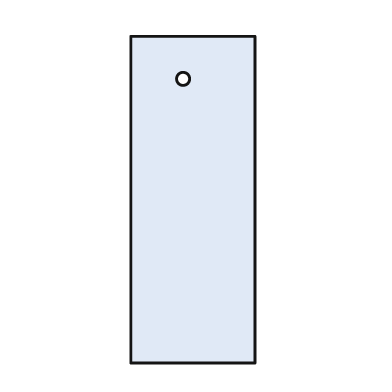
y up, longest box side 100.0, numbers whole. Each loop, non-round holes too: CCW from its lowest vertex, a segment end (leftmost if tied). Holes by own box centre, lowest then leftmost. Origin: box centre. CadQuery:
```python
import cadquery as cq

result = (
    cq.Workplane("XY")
    .moveTo(-19.0, -50.0)
    .lineTo(19.0, -50.0)
    .lineTo(19.0, 50.0)
    .lineTo(-19.0, 50.0)
    .close()
    .moveTo(-3.0, 37.0)
    .circle(2.0)
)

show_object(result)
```